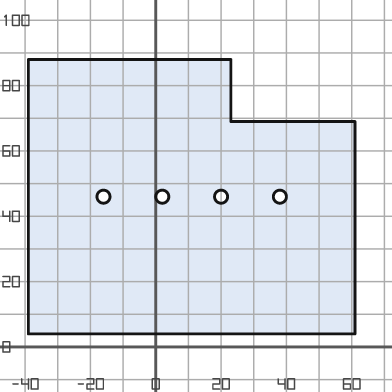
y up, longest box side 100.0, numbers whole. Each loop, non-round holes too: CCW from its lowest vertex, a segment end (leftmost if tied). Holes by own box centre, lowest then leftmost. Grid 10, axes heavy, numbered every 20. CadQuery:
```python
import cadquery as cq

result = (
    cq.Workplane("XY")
    .moveTo(-39.0, 4.0)
    .lineTo(61.0, 4.0)
    .lineTo(61.0, 69.0)
    .lineTo(23.0, 69.0)
    .lineTo(23.0, 88.0)
    .lineTo(-39.0, 88.0)
    .close()
    .moveTo(-16.0, 46.0)
    .circle(2.0)
    .moveTo(2.0, 46.0)
    .circle(2.0)
    .moveTo(20.0, 46.0)
    .circle(2.0)
    .moveTo(38.0, 46.0)
    .circle(2.0)
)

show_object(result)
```